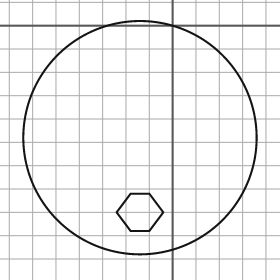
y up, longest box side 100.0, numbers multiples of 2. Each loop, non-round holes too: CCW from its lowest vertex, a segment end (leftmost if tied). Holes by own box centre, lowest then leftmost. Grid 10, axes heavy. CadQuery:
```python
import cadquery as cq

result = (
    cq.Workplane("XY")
    .moveTo(-14.0, -48.0)
    .circle(50.0)
    .moveTo(-18.0, -88.0)
    .lineTo(-10.0, -88.0)
    .lineTo(-4.0, -80.0)
    .lineTo(-10.0, -72.0)
    .lineTo(-18.0, -72.0)
    .lineTo(-24.0, -80.0)
    .close()
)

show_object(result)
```